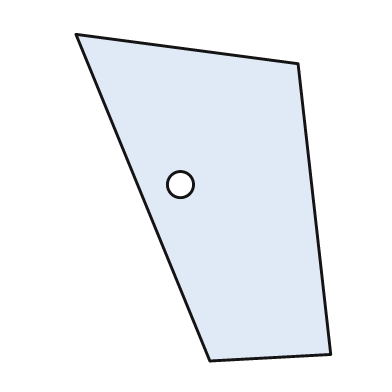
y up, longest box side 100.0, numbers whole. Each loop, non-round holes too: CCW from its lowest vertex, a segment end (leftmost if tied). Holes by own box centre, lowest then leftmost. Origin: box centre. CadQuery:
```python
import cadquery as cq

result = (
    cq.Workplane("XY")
    .moveTo(2.0, -50.0)
    .lineTo(39.0, -48.0)
    .lineTo(29.0, 41.0)
    .lineTo(-39.0, 50.0)
    .close()
    .moveTo(-7.0, 4.0)
    .circle(4.0)
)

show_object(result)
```